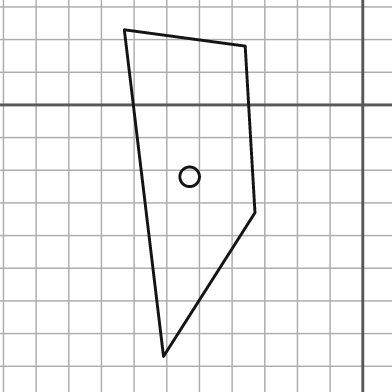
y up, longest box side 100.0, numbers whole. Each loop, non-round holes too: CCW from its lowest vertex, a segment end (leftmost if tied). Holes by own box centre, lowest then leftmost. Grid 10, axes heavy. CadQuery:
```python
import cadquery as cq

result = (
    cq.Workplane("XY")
    .moveTo(-61.0, -77.0)
    .lineTo(-33.0, -33.0)
    .lineTo(-36.0, 18.0)
    .lineTo(-73.0, 23.0)
    .close()
    .moveTo(-53.0, -22.0)
    .circle(3.0)
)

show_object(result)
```